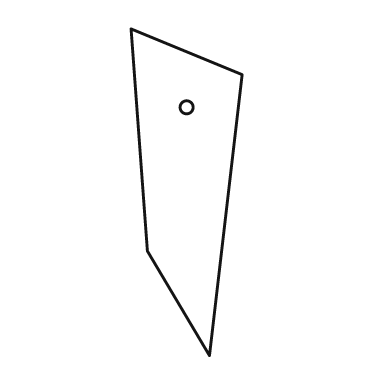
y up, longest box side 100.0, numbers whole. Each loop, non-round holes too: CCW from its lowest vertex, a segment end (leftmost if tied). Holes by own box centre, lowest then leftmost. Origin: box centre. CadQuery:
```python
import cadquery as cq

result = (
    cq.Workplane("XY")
    .moveTo(7.0, -50.0)
    .lineTo(17.0, 36.0)
    .lineTo(-17.0, 50.0)
    .lineTo(-12.0, -18.0)
    .close()
    .moveTo(0.0, 26.0)
    .circle(2.0)
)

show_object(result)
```